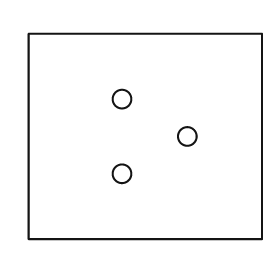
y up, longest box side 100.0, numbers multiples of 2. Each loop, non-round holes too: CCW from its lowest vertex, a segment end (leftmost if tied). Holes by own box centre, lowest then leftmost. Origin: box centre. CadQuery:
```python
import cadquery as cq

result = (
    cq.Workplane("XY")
    .moveTo(-50.0, -44.0)
    .lineTo(50.0, -44.0)
    .lineTo(50.0, 44.0)
    .lineTo(-50.0, 44.0)
    .close()
    .moveTo(-10.0, -16.0)
    .circle(4.0)
    .moveTo(18.0, 0.0)
    .circle(4.0)
    .moveTo(-10.0, 16.0)
    .circle(4.0)
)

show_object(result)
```